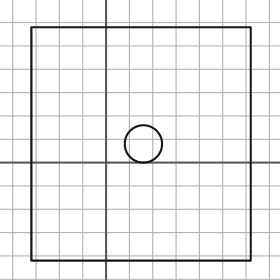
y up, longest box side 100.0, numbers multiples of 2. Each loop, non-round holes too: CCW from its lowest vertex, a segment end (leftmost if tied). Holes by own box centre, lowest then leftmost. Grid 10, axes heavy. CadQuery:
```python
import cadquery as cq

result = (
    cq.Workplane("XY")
    .moveTo(-32.0, -42.0)
    .lineTo(62.0, -42.0)
    .lineTo(62.0, 58.0)
    .lineTo(-32.0, 58.0)
    .close()
    .moveTo(16.0, 8.0)
    .circle(8.0)
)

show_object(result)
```